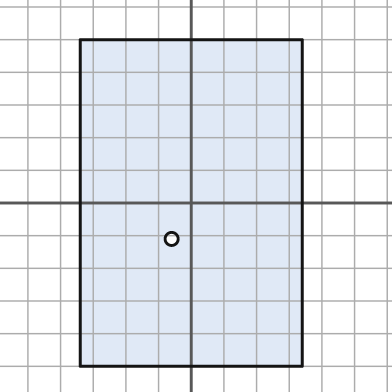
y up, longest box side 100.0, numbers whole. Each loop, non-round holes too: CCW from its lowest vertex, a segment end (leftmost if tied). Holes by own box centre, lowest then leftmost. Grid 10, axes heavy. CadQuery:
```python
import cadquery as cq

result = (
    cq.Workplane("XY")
    .moveTo(-34.0, -50.0)
    .lineTo(34.0, -50.0)
    .lineTo(34.0, 50.0)
    .lineTo(-34.0, 50.0)
    .close()
    .moveTo(-6.0, -11.0)
    .circle(2.0)
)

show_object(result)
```